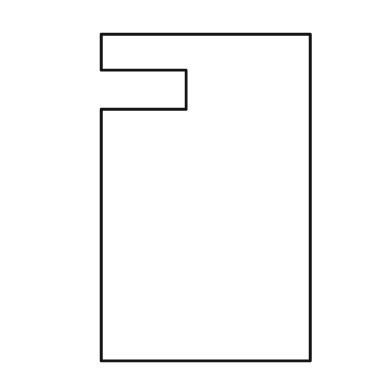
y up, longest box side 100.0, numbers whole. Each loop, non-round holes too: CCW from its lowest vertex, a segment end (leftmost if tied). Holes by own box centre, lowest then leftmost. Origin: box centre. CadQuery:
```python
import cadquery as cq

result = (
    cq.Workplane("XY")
    .moveTo(-32.0, -50.0)
    .lineTo(32.0, -50.0)
    .lineTo(32.0, 50.0)
    .lineTo(-32.0, 50.0)
    .lineTo(-32.0, 39.0)
    .lineTo(-6.0, 39.0)
    .lineTo(-6.0, 27.0)
    .lineTo(-32.0, 27.0)
    .close()
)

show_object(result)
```